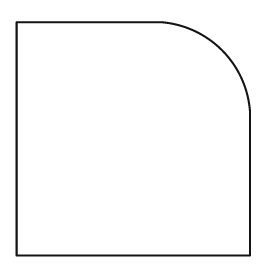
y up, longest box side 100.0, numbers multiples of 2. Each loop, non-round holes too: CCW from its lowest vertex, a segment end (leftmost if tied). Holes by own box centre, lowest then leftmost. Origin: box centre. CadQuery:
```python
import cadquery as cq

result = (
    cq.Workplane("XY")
    .moveTo(-50.0, -50.0)
    .lineTo(50.0, -50.0)
    .lineTo(50.0, 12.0)
    .threePointArc((38.0, 38.0), (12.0, 50.0))
    .lineTo(-50.0, 50.0)
    .close()
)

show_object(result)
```